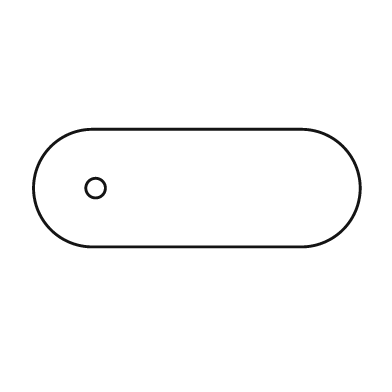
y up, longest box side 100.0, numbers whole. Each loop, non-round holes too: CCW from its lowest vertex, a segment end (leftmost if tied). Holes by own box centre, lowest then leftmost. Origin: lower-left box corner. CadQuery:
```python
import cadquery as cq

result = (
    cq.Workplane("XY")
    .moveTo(18.0, 0.0)
    .lineTo(82.0, 0.0)
    .threePointArc((100.0, 18.0), (82.0, 36.0))
    .lineTo(18.0, 36.0)
    .threePointArc((0.0, 18.0), (18.0, 0.0))
    .close()
    .moveTo(19.0, 18.0)
    .circle(3.0)
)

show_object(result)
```